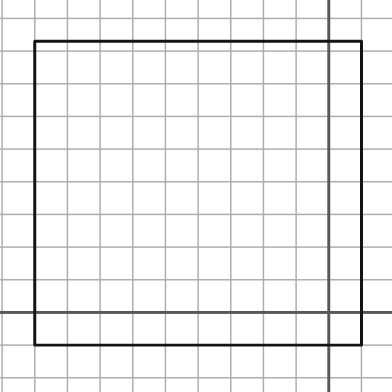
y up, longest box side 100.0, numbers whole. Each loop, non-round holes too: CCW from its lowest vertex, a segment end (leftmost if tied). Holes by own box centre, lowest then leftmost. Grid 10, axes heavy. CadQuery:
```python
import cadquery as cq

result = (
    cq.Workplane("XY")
    .moveTo(-90.0, -10.0)
    .lineTo(10.0, -10.0)
    .lineTo(10.0, 83.0)
    .lineTo(-90.0, 83.0)
    .close()
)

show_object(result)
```